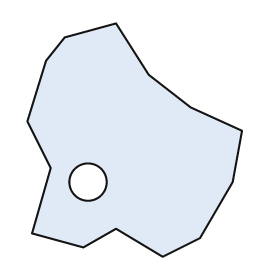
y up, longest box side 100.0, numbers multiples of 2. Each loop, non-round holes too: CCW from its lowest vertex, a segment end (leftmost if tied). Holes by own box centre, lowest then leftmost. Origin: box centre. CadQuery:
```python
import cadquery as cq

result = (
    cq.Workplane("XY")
    .moveTo(12.0, -50.0)
    .lineTo(28.0, -42.0)
    .lineTo(42.0, -18.0)
    .lineTo(46.0, 4.0)
    .lineTo(24.0, 14.0)
    .lineTo(6.0, 28.0)
    .lineTo(-8.0, 50.0)
    .lineTo(-30.0, 44.0)
    .lineTo(-38.0, 34.0)
    .lineTo(-46.0, 8.0)
    .lineTo(-36.0, -12.0)
    .lineTo(-44.0, -40.0)
    .lineTo(-22.0, -46.0)
    .lineTo(-8.0, -38.0)
    .close()
    .moveTo(-20.0, -18.0)
    .circle(8.0)
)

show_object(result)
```